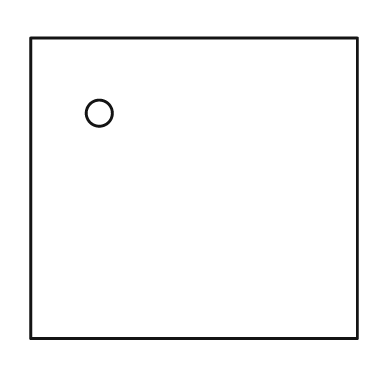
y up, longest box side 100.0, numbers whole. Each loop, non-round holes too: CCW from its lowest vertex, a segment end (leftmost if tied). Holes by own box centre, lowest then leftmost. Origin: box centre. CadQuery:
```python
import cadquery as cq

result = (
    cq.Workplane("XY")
    .moveTo(-50.0, -46.0)
    .lineTo(50.0, -46.0)
    .lineTo(50.0, 46.0)
    .lineTo(-50.0, 46.0)
    .close()
    .moveTo(-29.0, 23.0)
    .circle(4.0)
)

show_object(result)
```